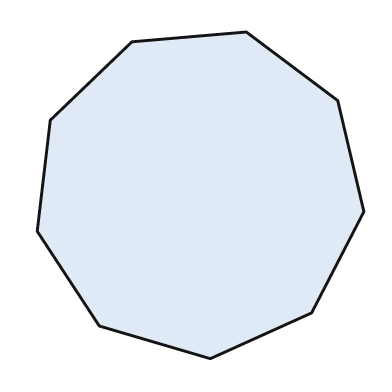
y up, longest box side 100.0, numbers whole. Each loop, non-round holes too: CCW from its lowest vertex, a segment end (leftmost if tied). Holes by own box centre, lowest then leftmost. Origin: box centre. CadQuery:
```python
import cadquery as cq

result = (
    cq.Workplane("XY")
    .moveTo(3.0, -50.0)
    .lineTo(34.0, -36.0)
    .lineTo(50.0, -5.0)
    .lineTo(42.0, 29.0)
    .lineTo(14.0, 50.0)
    .lineTo(-21.0, 47.0)
    .lineTo(-46.0, 23.0)
    .lineTo(-50.0, -11.0)
    .lineTo(-31.0, -40.0)
    .close()
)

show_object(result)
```